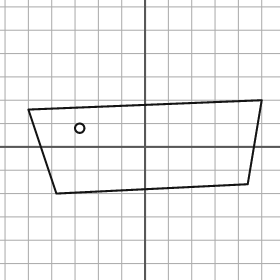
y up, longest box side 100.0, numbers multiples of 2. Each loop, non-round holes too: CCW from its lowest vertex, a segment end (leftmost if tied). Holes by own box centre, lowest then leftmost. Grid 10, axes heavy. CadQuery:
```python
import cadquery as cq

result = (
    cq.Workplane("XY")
    .moveTo(-38.0, -20.0)
    .lineTo(44.0, -16.0)
    .lineTo(50.0, 20.0)
    .lineTo(-50.0, 16.0)
    .close()
    .moveTo(-28.0, 8.0)
    .circle(2.0)
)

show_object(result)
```